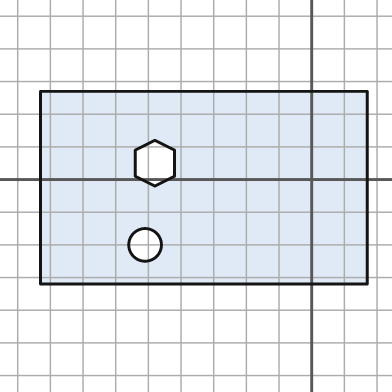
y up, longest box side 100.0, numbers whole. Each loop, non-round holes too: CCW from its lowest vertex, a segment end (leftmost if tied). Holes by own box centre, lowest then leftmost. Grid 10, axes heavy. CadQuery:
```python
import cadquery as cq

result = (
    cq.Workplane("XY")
    .moveTo(-83.0, -32.0)
    .lineTo(17.0, -32.0)
    .lineTo(17.0, 27.0)
    .lineTo(-83.0, 27.0)
    .close()
    .moveTo(-51.0, -20.0)
    .circle(5.0)
    .moveTo(-48.0, -2.0)
    .lineTo(-42.0, 1.0)
    .lineTo(-42.0, 9.0)
    .lineTo(-48.0, 12.0)
    .lineTo(-54.0, 9.0)
    .lineTo(-54.0, 1.0)
    .close()
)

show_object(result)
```